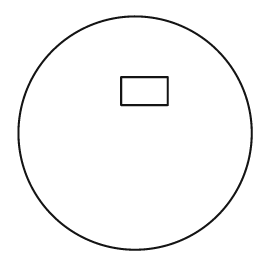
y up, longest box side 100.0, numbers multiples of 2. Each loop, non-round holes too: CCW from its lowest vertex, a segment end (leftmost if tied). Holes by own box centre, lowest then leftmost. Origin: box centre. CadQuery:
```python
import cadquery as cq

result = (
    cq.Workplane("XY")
    .moveTo(0.0, 0.0)
    .circle(50.0)
    .moveTo(-6.0, 12.0)
    .lineTo(14.0, 12.0)
    .lineTo(14.0, 24.0)
    .lineTo(-6.0, 24.0)
    .close()
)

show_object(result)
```